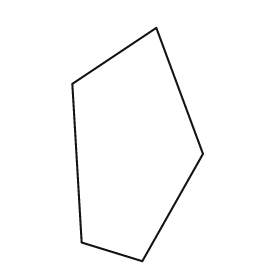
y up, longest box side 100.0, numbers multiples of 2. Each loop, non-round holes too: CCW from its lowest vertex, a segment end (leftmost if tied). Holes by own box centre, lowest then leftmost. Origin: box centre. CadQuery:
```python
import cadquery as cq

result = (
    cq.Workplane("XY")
    .moveTo(2.0, -50.0)
    .lineTo(28.0, -4.0)
    .lineTo(8.0, 50.0)
    .lineTo(-28.0, 26.0)
    .lineTo(-24.0, -42.0)
    .close()
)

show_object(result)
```